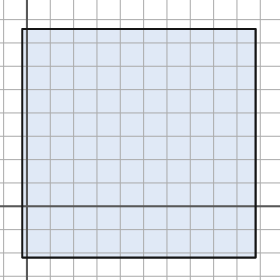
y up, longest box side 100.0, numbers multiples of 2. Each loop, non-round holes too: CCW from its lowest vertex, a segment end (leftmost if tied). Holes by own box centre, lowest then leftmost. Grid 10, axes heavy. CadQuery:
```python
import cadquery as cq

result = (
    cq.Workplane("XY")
    .moveTo(-2.0, -22.0)
    .lineTo(98.0, -22.0)
    .lineTo(98.0, 76.0)
    .lineTo(-2.0, 76.0)
    .close()
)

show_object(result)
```